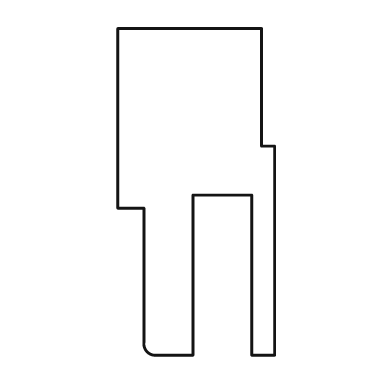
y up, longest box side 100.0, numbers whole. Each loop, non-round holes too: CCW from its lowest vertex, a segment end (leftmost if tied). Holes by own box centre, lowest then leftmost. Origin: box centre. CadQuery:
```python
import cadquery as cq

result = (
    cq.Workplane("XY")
    .moveTo(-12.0, -50.0)
    .lineTo(-1.0, -50.0)
    .lineTo(-1.0, -1.0)
    .lineTo(17.0, -1.0)
    .lineTo(17.0, -50.0)
    .lineTo(24.0, -50.0)
    .lineTo(24.0, 14.0)
    .lineTo(20.0, 14.0)
    .lineTo(20.0, 50.0)
    .lineTo(-24.0, 50.0)
    .lineTo(-24.0, -5.0)
    .lineTo(-16.0, -5.0)
    .lineTo(-16.0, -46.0)
    .threePointArc((-15.0, -49.0), (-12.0, -50.0))
    .close()
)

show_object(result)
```